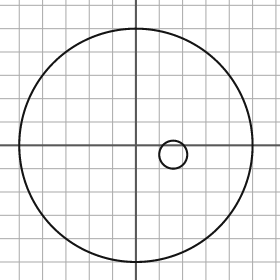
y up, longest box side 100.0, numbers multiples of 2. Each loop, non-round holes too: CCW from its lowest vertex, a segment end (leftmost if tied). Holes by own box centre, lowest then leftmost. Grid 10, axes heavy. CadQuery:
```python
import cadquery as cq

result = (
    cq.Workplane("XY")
    .moveTo(0.0, 0.0)
    .circle(50.0)
    .moveTo(16.0, -4.0)
    .circle(6.0)
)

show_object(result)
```